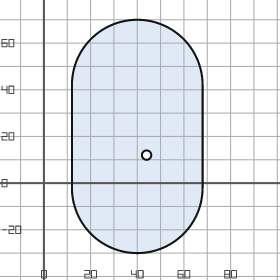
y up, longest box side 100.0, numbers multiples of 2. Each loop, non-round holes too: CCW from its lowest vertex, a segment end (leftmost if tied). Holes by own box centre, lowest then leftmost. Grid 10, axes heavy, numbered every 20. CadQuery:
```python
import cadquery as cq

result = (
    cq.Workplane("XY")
    .moveTo(12.0, -2.0)
    .threePointArc((40.0, -30.0), (68.0, -2.0))
    .lineTo(68.0, 42.0)
    .threePointArc((40.0, 70.0), (12.0, 42.0))
    .close()
    .moveTo(44.0, 12.0)
    .circle(2.0)
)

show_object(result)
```